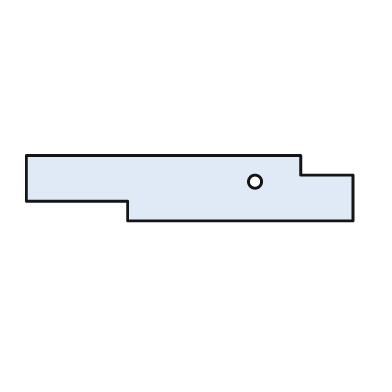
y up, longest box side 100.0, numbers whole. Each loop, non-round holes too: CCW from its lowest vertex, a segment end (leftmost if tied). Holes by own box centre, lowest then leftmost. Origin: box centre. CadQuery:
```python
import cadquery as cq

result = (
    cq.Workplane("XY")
    .moveTo(-19.0, -10.0)
    .lineTo(50.0, -10.0)
    .lineTo(50.0, 4.0)
    .lineTo(34.0, 4.0)
    .lineTo(34.0, 10.0)
    .lineTo(-50.0, 10.0)
    .lineTo(-50.0, -4.0)
    .lineTo(-19.0, -4.0)
    .close()
    .moveTo(20.0, 2.0)
    .circle(2.0)
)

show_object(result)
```